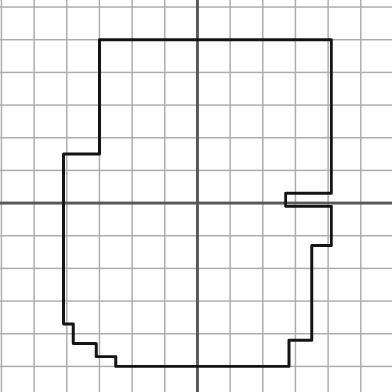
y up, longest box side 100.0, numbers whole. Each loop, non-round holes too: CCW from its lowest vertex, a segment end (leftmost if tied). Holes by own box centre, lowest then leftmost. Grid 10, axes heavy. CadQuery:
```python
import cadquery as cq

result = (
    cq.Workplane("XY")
    .moveTo(-25.0, -50.0)
    .lineTo(28.0, -50.0)
    .lineTo(28.0, -42.0)
    .lineTo(35.0, -42.0)
    .lineTo(35.0, -13.0)
    .lineTo(41.0, -13.0)
    .lineTo(41.0, -1.0)
    .lineTo(27.0, -1.0)
    .lineTo(27.0, 3.0)
    .lineTo(41.0, 3.0)
    .lineTo(41.0, 50.0)
    .lineTo(-30.0, 50.0)
    .lineTo(-30.0, 15.0)
    .lineTo(-41.0, 15.0)
    .lineTo(-41.0, -37.0)
    .lineTo(-38.0, -37.0)
    .lineTo(-38.0, -43.0)
    .lineTo(-31.0, -43.0)
    .lineTo(-31.0, -47.0)
    .lineTo(-25.0, -47.0)
    .close()
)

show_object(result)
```